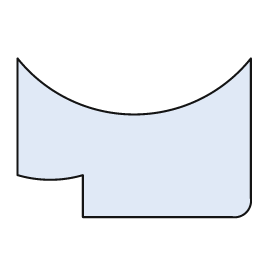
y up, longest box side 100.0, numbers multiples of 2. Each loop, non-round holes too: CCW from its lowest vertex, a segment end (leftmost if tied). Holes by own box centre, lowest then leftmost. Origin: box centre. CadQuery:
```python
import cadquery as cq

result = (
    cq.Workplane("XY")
    .moveTo(-22.0, -34.0)
    .lineTo(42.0, -34.0)
    .threePointArc((48.0, -32.0), (50.0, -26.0))
    .lineTo(50.0, 34.0)
    .threePointArc((0.0, 10.0), (-50.0, 34.0))
    .lineTo(-50.0, -16.0)
    .threePointArc((-36.0, -18.0), (-22.0, -16.0))
    .close()
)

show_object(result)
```